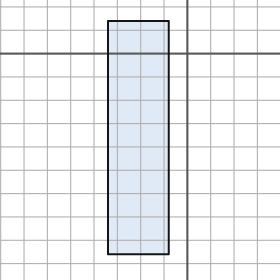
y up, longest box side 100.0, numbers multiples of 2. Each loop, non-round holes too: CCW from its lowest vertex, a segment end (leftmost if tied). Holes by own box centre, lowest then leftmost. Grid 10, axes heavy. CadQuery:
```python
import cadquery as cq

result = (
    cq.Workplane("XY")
    .moveTo(-34.0, -86.0)
    .lineTo(-8.0, -86.0)
    .lineTo(-8.0, 14.0)
    .lineTo(-34.0, 14.0)
    .close()
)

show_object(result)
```